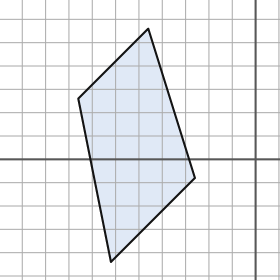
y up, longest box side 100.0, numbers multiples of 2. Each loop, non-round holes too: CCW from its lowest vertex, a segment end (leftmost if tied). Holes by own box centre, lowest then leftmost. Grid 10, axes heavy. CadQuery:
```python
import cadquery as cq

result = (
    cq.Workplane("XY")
    .moveTo(-62.0, -44.0)
    .lineTo(-26.0, -8.0)
    .lineTo(-46.0, 56.0)
    .lineTo(-76.0, 26.0)
    .close()
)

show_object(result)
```